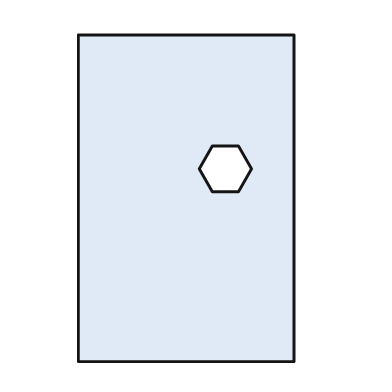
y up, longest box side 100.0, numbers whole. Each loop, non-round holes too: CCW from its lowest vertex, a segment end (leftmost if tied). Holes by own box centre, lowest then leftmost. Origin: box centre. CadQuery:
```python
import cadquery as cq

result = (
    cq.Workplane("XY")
    .moveTo(-33.0, -50.0)
    .lineTo(33.0, -50.0)
    .lineTo(33.0, 50.0)
    .lineTo(-33.0, 50.0)
    .close()
    .moveTo(8.0, 2.0)
    .lineTo(16.0, 2.0)
    .lineTo(20.0, 9.0)
    .lineTo(16.0, 16.0)
    .lineTo(8.0, 16.0)
    .lineTo(4.0, 9.0)
    .close()
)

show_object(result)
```